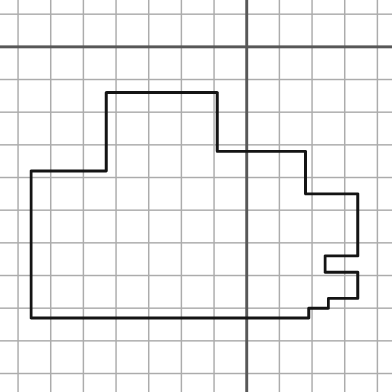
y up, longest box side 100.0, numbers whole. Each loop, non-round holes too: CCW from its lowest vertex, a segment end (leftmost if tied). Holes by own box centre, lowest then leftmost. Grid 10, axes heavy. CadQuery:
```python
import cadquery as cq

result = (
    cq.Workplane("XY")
    .moveTo(-66.0, -83.0)
    .lineTo(19.0, -83.0)
    .lineTo(19.0, -80.0)
    .lineTo(25.0, -80.0)
    .lineTo(25.0, -77.0)
    .lineTo(34.0, -77.0)
    .lineTo(34.0, -69.0)
    .lineTo(24.0, -69.0)
    .lineTo(24.0, -64.0)
    .lineTo(34.0, -64.0)
    .lineTo(34.0, -45.0)
    .lineTo(18.0, -45.0)
    .lineTo(18.0, -32.0)
    .lineTo(-9.0, -32.0)
    .lineTo(-9.0, -14.0)
    .lineTo(-43.0, -14.0)
    .lineTo(-43.0, -38.0)
    .lineTo(-66.0, -38.0)
    .close()
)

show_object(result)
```